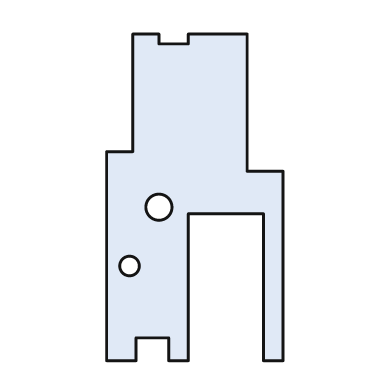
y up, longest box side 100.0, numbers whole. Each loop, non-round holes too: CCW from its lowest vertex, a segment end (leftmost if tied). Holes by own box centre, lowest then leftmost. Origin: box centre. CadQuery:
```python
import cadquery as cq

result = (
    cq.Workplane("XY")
    .moveTo(-27.0, -50.0)
    .lineTo(-18.0, -50.0)
    .lineTo(-18.0, -43.0)
    .lineTo(-8.0, -43.0)
    .lineTo(-8.0, -50.0)
    .lineTo(-2.0, -50.0)
    .lineTo(-2.0, -5.0)
    .lineTo(21.0, -5.0)
    .lineTo(21.0, -50.0)
    .lineTo(27.0, -50.0)
    .lineTo(27.0, 8.0)
    .lineTo(16.0, 8.0)
    .lineTo(16.0, 50.0)
    .lineTo(-2.0, 50.0)
    .lineTo(-2.0, 47.0)
    .lineTo(-11.0, 47.0)
    .lineTo(-11.0, 50.0)
    .lineTo(-19.0, 50.0)
    .lineTo(-19.0, 14.0)
    .lineTo(-27.0, 14.0)
    .close()
    .moveTo(-20.0, -21.0)
    .circle(3.0)
    .moveTo(-11.0, -3.0)
    .circle(4.0)
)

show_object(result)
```